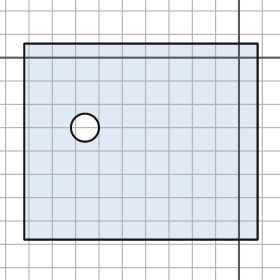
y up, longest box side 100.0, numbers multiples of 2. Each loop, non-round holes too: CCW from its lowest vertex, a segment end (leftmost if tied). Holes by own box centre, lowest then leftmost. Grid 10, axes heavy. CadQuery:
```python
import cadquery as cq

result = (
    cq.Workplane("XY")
    .moveTo(-92.0, -78.0)
    .lineTo(8.0, -78.0)
    .lineTo(8.0, 6.0)
    .lineTo(-92.0, 6.0)
    .close()
    .moveTo(-66.0, -30.0)
    .circle(6.0)
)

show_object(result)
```